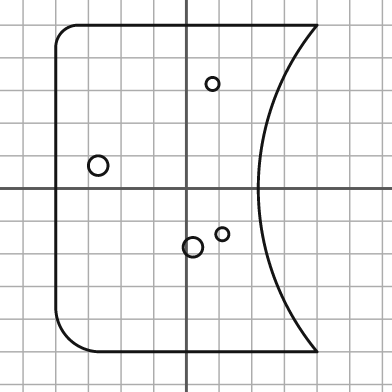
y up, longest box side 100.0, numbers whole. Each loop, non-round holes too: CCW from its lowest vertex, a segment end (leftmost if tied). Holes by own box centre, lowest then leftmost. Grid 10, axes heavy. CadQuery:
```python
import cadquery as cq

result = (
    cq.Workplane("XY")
    .moveTo(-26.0, -50.0)
    .lineTo(40.0, -50.0)
    .threePointArc((22.0, 0.0), (40.0, 50.0))
    .lineTo(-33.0, 50.0)
    .threePointArc((-38.0, 48.0), (-40.0, 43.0))
    .lineTo(-40.0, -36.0)
    .threePointArc((-36.0, -46.0), (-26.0, -50.0))
    .close()
    .moveTo(2.0, -18.0)
    .circle(3.0)
    .moveTo(11.0, -14.0)
    .circle(2.0)
    .moveTo(-27.0, 7.0)
    .circle(3.0)
    .moveTo(8.0, 32.0)
    .circle(2.0)
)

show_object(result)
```